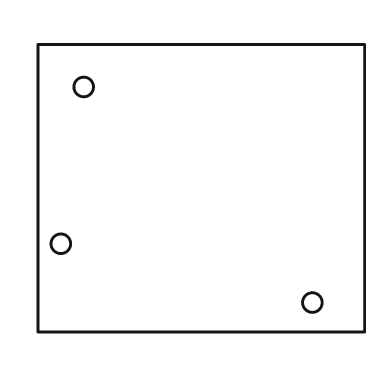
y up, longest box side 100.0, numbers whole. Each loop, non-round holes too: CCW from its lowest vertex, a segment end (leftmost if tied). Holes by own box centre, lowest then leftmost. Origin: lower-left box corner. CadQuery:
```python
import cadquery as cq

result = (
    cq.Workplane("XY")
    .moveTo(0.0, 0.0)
    .lineTo(100.0, 0.0)
    .lineTo(100.0, 88.0)
    .lineTo(0.0, 88.0)
    .close()
    .moveTo(84.0, 9.0)
    .circle(3.0)
    .moveTo(7.0, 27.0)
    .circle(3.0)
    .moveTo(14.0, 75.0)
    .circle(3.0)
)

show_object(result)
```